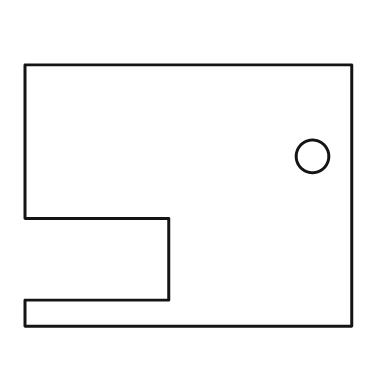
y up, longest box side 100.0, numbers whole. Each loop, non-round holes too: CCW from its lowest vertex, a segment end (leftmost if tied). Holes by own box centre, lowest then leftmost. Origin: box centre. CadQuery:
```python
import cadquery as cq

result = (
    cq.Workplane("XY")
    .moveTo(-50.0, -40.0)
    .lineTo(50.0, -40.0)
    .lineTo(50.0, 40.0)
    .lineTo(-50.0, 40.0)
    .lineTo(-50.0, -7.0)
    .lineTo(-6.0, -7.0)
    .lineTo(-6.0, -32.0)
    .lineTo(-50.0, -32.0)
    .close()
    .moveTo(38.0, 12.0)
    .circle(5.0)
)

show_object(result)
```